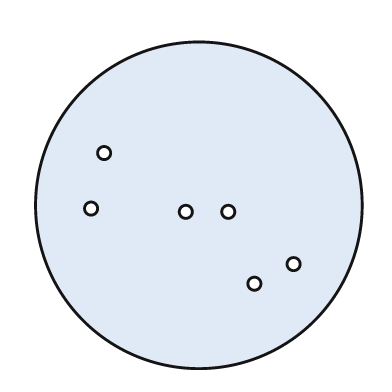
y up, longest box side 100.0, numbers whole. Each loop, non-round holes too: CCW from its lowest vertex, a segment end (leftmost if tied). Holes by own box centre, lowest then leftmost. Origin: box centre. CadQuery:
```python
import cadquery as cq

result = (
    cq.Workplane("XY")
    .moveTo(0.0, 0.0)
    .circle(50.0)
    .moveTo(17.0, -24.0)
    .circle(2.0)
    .moveTo(29.0, -18.0)
    .circle(2.0)
    .moveTo(-4.0, -2.0)
    .circle(2.0)
    .moveTo(9.0, -2.0)
    .circle(2.0)
    .moveTo(-33.0, -1.0)
    .circle(2.0)
    .moveTo(-29.0, 16.0)
    .circle(2.0)
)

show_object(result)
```